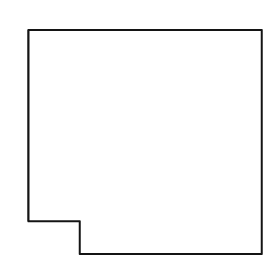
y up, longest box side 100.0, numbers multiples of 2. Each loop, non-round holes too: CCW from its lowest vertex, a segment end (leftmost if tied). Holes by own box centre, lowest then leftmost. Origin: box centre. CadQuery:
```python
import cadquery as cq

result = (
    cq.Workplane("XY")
    .moveTo(-28.0, -48.0)
    .lineTo(50.0, -48.0)
    .lineTo(50.0, 48.0)
    .lineTo(-50.0, 48.0)
    .lineTo(-50.0, -34.0)
    .lineTo(-28.0, -34.0)
    .close()
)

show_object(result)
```